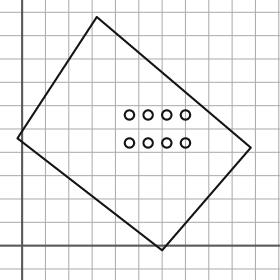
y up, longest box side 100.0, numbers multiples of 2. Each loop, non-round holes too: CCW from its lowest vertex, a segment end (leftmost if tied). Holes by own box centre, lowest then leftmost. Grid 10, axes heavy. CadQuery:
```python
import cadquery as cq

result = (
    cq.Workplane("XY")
    .moveTo(60.0, -2.0)
    .lineTo(98.0, 42.0)
    .lineTo(32.0, 98.0)
    .lineTo(-2.0, 46.0)
    .close()
    .moveTo(46.0, 44.0)
    .circle(2.0)
    .moveTo(54.0, 44.0)
    .circle(2.0)
    .moveTo(62.0, 44.0)
    .circle(2.0)
    .moveTo(70.0, 44.0)
    .circle(2.0)
    .moveTo(46.0, 56.0)
    .circle(2.0)
    .moveTo(54.0, 56.0)
    .circle(2.0)
    .moveTo(62.0, 56.0)
    .circle(2.0)
    .moveTo(70.0, 56.0)
    .circle(2.0)
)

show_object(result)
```